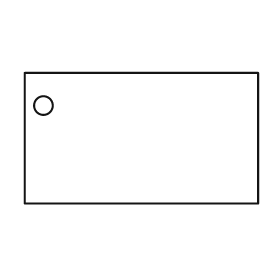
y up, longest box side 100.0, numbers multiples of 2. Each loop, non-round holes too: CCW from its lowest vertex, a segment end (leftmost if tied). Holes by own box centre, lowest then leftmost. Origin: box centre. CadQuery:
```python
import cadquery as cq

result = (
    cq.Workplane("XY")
    .moveTo(-50.0, -28.0)
    .lineTo(50.0, -28.0)
    .lineTo(50.0, 28.0)
    .lineTo(-50.0, 28.0)
    .close()
    .moveTo(-42.0, 14.0)
    .circle(4.0)
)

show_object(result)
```